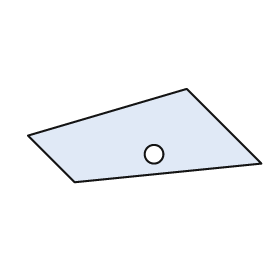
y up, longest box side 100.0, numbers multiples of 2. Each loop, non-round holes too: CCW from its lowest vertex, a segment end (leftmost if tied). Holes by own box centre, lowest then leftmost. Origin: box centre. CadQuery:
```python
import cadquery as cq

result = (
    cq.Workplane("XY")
    .moveTo(-30.0, -20.0)
    .lineTo(50.0, -12.0)
    .lineTo(18.0, 20.0)
    .lineTo(-50.0, 0.0)
    .close()
    .moveTo(4.0, -8.0)
    .circle(4.0)
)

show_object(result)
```